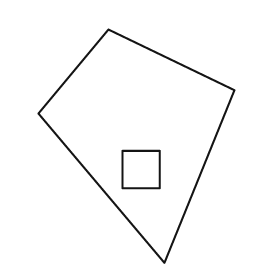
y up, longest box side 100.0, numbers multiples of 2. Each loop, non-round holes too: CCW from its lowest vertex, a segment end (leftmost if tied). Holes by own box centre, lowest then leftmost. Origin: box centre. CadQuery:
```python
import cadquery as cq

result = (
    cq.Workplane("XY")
    .moveTo(12.0, -50.0)
    .lineTo(42.0, 24.0)
    .lineTo(-12.0, 50.0)
    .lineTo(-42.0, 14.0)
    .close()
    .moveTo(-6.0, -18.0)
    .lineTo(10.0, -18.0)
    .lineTo(10.0, -2.0)
    .lineTo(-6.0, -2.0)
    .close()
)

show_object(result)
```